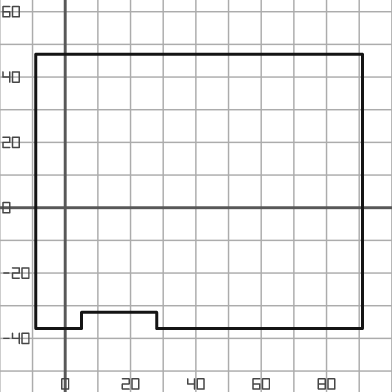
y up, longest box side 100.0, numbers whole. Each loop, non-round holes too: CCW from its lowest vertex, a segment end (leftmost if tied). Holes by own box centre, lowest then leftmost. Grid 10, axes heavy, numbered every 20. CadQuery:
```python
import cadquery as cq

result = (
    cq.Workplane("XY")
    .moveTo(-9.0, -37.0)
    .lineTo(5.0, -37.0)
    .lineTo(5.0, -32.0)
    .lineTo(28.0, -32.0)
    .lineTo(28.0, -37.0)
    .lineTo(91.0, -37.0)
    .lineTo(91.0, 47.0)
    .lineTo(-9.0, 47.0)
    .close()
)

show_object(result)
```